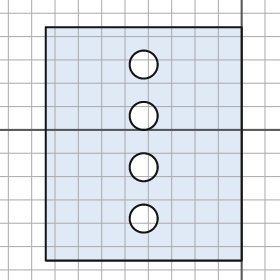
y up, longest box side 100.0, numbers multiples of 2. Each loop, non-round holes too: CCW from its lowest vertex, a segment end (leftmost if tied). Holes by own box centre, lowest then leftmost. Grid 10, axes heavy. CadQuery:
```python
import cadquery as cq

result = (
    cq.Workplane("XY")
    .moveTo(-84.0, -56.0)
    .lineTo(0.0, -56.0)
    .lineTo(0.0, 44.0)
    .lineTo(-84.0, 44.0)
    .close()
    .moveTo(-42.0, -38.0)
    .circle(6.0)
    .moveTo(-42.0, -16.0)
    .circle(6.0)
    .moveTo(-42.0, 6.0)
    .circle(6.0)
    .moveTo(-42.0, 28.0)
    .circle(6.0)
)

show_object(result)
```